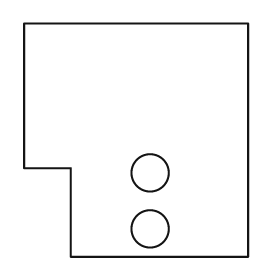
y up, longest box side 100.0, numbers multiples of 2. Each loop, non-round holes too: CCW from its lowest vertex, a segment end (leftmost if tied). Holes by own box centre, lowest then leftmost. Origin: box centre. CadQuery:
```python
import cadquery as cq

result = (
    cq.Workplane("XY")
    .moveTo(-28.0, -50.0)
    .lineTo(48.0, -50.0)
    .lineTo(48.0, 50.0)
    .lineTo(-48.0, 50.0)
    .lineTo(-48.0, -12.0)
    .lineTo(-28.0, -12.0)
    .close()
    .moveTo(6.0, -38.0)
    .circle(8.0)
    .moveTo(6.0, -14.0)
    .circle(8.0)
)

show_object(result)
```